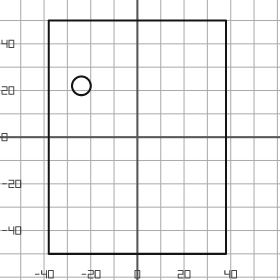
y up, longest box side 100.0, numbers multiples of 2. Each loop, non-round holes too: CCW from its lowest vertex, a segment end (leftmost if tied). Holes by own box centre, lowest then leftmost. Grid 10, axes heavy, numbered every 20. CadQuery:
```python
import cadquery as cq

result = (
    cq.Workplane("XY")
    .moveTo(-38.0, -50.0)
    .lineTo(38.0, -50.0)
    .lineTo(38.0, 50.0)
    .lineTo(-38.0, 50.0)
    .close()
    .moveTo(-24.0, 22.0)
    .circle(4.0)
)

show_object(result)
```